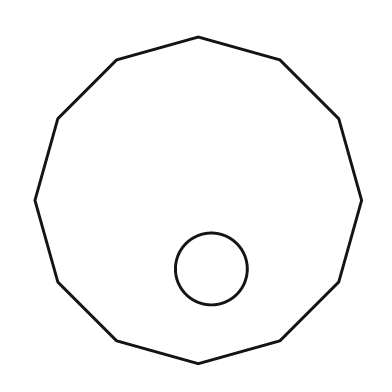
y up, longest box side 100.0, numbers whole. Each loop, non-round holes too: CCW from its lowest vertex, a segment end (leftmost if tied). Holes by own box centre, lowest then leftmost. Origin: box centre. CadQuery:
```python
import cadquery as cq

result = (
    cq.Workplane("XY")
    .moveTo(0.0, -50.0)
    .lineTo(25.0, -43.0)
    .lineTo(43.0, -25.0)
    .lineTo(50.0, 0.0)
    .lineTo(43.0, 25.0)
    .lineTo(25.0, 43.0)
    .lineTo(0.0, 50.0)
    .lineTo(-25.0, 43.0)
    .lineTo(-43.0, 25.0)
    .lineTo(-50.0, 0.0)
    .lineTo(-43.0, -25.0)
    .lineTo(-25.0, -43.0)
    .close()
    .moveTo(4.0, -21.0)
    .circle(11.0)
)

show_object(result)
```